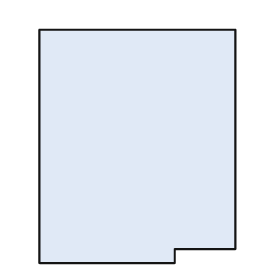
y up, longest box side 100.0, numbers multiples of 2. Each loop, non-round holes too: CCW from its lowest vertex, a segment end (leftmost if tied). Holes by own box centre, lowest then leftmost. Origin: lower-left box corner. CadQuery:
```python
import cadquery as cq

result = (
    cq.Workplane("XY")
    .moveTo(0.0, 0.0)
    .lineTo(58.0, 0.0)
    .lineTo(58.0, 6.0)
    .lineTo(84.0, 6.0)
    .lineTo(84.0, 100.0)
    .lineTo(0.0, 100.0)
    .close()
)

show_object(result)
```